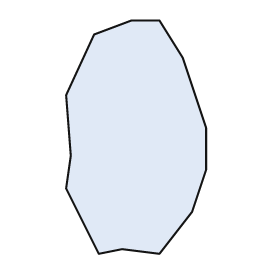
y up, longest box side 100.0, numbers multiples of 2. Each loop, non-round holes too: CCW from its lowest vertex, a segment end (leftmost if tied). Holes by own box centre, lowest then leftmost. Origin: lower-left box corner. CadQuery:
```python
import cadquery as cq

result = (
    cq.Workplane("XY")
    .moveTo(14.0, 0.0)
    .lineTo(24.0, 2.0)
    .lineTo(40.0, 0.0)
    .lineTo(54.0, 18.0)
    .lineTo(60.0, 36.0)
    .lineTo(60.0, 54.0)
    .lineTo(50.0, 84.0)
    .lineTo(40.0, 100.0)
    .lineTo(28.0, 100.0)
    .lineTo(12.0, 94.0)
    .lineTo(0.0, 68.0)
    .lineTo(2.0, 42.0)
    .lineTo(0.0, 28.0)
    .close()
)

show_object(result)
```